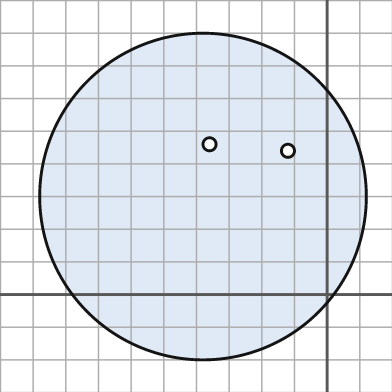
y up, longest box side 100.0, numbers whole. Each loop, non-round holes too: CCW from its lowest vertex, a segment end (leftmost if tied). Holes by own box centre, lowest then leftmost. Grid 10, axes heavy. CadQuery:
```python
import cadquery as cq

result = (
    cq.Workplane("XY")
    .moveTo(-38.0, 30.0)
    .circle(50.0)
    .moveTo(-12.0, 44.0)
    .circle(2.0)
    .moveTo(-36.0, 46.0)
    .circle(2.0)
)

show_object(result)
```